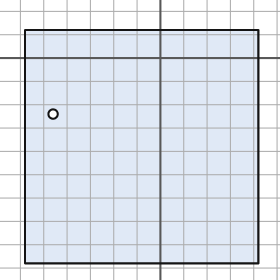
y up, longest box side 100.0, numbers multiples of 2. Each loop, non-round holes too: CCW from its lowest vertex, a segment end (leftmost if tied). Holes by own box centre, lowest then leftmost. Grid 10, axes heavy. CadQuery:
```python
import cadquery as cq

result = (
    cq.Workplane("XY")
    .moveTo(-58.0, -88.0)
    .lineTo(42.0, -88.0)
    .lineTo(42.0, 12.0)
    .lineTo(-58.0, 12.0)
    .close()
    .moveTo(-46.0, -24.0)
    .circle(2.0)
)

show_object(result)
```